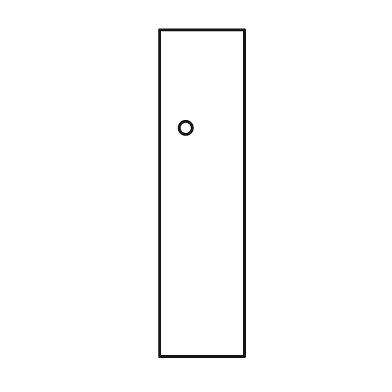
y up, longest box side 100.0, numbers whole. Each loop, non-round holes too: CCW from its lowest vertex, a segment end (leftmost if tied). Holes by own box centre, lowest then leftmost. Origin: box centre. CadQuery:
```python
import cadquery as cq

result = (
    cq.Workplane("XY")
    .moveTo(-13.0, -50.0)
    .lineTo(13.0, -50.0)
    .lineTo(13.0, 50.0)
    .lineTo(-13.0, 50.0)
    .close()
    .moveTo(-5.0, 20.0)
    .circle(2.0)
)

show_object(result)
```